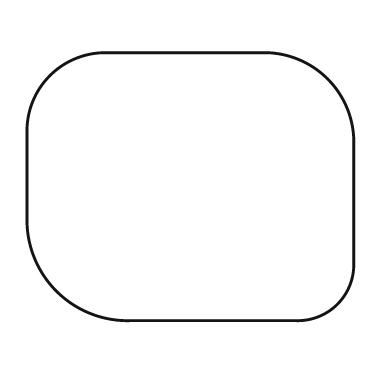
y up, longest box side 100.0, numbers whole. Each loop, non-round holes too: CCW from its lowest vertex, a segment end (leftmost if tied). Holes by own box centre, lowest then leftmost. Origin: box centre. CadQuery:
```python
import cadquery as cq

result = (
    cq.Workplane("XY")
    .moveTo(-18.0, -41.0)
    .lineTo(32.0, -41.0)
    .threePointArc((45.0, -36.0), (50.0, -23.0))
    .lineTo(50.0, 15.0)
    .threePointArc((42.0, 33.0), (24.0, 41.0))
    .lineTo(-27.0, 41.0)
    .threePointArc((-43.0, 34.0), (-50.0, 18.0))
    .lineTo(-50.0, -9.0)
    .threePointArc((-41.0, -32.0), (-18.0, -41.0))
    .close()
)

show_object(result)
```